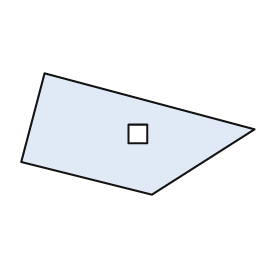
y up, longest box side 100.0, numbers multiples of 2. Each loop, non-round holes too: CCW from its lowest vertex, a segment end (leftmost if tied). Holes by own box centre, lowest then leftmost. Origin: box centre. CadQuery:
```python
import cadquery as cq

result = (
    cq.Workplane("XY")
    .moveTo(6.0, -26.0)
    .lineTo(50.0, 2.0)
    .lineTo(-40.0, 26.0)
    .lineTo(-50.0, -12.0)
    .close()
    .moveTo(-4.0, -4.0)
    .lineTo(4.0, -4.0)
    .lineTo(4.0, 4.0)
    .lineTo(-4.0, 4.0)
    .close()
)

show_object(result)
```